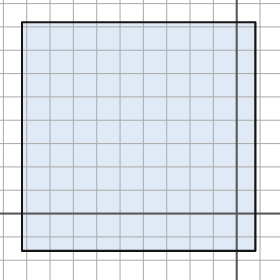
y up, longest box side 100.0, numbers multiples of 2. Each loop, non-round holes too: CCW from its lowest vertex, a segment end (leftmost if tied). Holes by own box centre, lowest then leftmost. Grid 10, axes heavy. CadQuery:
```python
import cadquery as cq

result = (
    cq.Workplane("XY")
    .moveTo(-92.0, -16.0)
    .lineTo(8.0, -16.0)
    .lineTo(8.0, 82.0)
    .lineTo(-92.0, 82.0)
    .close()
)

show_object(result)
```